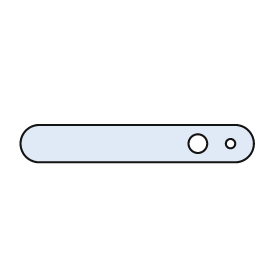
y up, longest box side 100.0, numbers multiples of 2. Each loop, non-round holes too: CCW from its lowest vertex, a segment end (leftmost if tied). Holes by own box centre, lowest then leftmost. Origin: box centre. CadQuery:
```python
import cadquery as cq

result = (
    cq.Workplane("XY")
    .moveTo(-42.0, -8.0)
    .lineTo(42.0, -8.0)
    .threePointArc((50.0, 0.0), (42.0, 8.0))
    .lineTo(-42.0, 8.0)
    .threePointArc((-50.0, 0.0), (-42.0, -8.0))
    .close()
    .moveTo(26.0, 0.0)
    .circle(4.0)
    .moveTo(40.0, 0.0)
    .circle(2.0)
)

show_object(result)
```